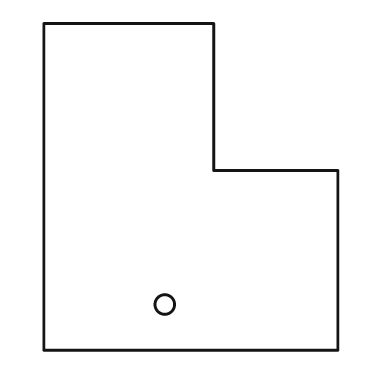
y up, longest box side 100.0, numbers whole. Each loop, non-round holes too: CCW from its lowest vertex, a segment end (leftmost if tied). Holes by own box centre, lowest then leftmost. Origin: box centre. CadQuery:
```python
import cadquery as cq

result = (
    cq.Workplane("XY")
    .moveTo(-45.0, -50.0)
    .lineTo(45.0, -50.0)
    .lineTo(45.0, 5.0)
    .lineTo(7.0, 5.0)
    .lineTo(7.0, 50.0)
    .lineTo(-45.0, 50.0)
    .close()
    .moveTo(-8.0, -36.0)
    .circle(3.0)
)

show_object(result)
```